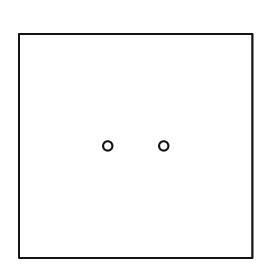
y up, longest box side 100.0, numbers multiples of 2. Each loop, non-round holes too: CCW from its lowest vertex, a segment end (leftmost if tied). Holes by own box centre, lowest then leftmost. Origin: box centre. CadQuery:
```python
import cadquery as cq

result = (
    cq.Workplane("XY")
    .moveTo(-50.0, -48.0)
    .lineTo(50.0, -48.0)
    .lineTo(50.0, 48.0)
    .lineTo(-50.0, 48.0)
    .close()
    .moveTo(-12.0, 0.0)
    .circle(2.0)
    .moveTo(12.0, 0.0)
    .circle(2.0)
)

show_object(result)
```